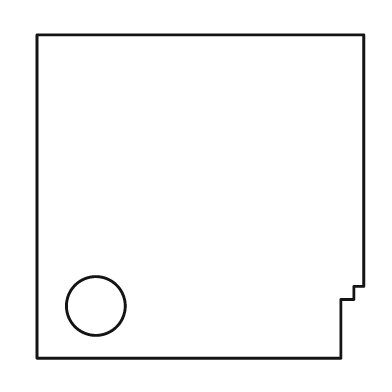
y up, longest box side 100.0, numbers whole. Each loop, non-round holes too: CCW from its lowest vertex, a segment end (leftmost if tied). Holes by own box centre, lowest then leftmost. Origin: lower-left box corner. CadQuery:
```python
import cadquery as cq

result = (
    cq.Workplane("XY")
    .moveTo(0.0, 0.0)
    .lineTo(93.0, 0.0)
    .lineTo(93.0, 18.0)
    .lineTo(97.0, 18.0)
    .lineTo(97.0, 22.0)
    .lineTo(100.0, 22.0)
    .lineTo(100.0, 99.0)
    .lineTo(0.0, 99.0)
    .close()
    .moveTo(18.0, 16.0)
    .circle(9.0)
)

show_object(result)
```